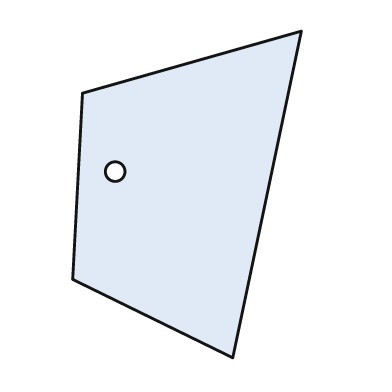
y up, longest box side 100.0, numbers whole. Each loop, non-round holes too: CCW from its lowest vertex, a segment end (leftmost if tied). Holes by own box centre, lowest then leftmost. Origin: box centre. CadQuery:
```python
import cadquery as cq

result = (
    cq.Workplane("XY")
    .moveTo(14.0, -50.0)
    .lineTo(35.0, 50.0)
    .lineTo(-32.0, 31.0)
    .lineTo(-35.0, -26.0)
    .close()
    .moveTo(-22.0, 7.0)
    .circle(3.0)
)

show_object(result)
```